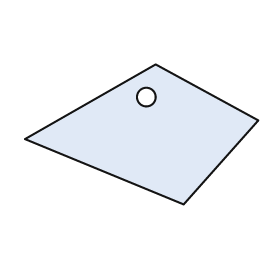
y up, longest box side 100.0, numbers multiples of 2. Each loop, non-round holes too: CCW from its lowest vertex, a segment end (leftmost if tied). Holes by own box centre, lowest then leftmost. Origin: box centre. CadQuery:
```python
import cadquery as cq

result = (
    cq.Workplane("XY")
    .moveTo(18.0, -30.0)
    .lineTo(50.0, 6.0)
    .lineTo(6.0, 30.0)
    .lineTo(-50.0, -2.0)
    .close()
    .moveTo(2.0, 16.0)
    .circle(4.0)
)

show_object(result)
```